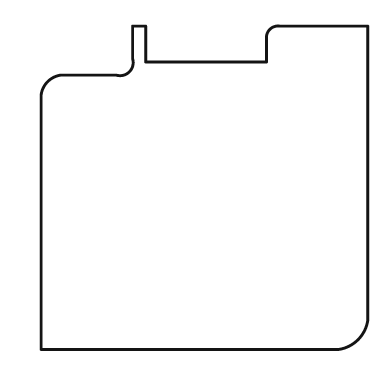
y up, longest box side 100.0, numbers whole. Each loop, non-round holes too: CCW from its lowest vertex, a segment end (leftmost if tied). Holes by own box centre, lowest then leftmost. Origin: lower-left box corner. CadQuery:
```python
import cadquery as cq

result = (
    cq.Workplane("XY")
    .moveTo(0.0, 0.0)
    .lineTo(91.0, 0.0)
    .threePointArc((97.0, 3.0), (100.0, 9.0))
    .lineTo(100.0, 99.0)
    .lineTo(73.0, 99.0)
    .threePointArc((70.0, 98.0), (69.0, 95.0))
    .lineTo(69.0, 88.0)
    .lineTo(32.0, 88.0)
    .lineTo(32.0, 99.0)
    .lineTo(28.0, 99.0)
    .lineTo(28.0, 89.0)
    .threePointArc((27.0, 85.0), (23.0, 84.0))
    .lineTo(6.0, 84.0)
    .threePointArc((2.0, 82.0), (0.0, 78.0))
    .close()
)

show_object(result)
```